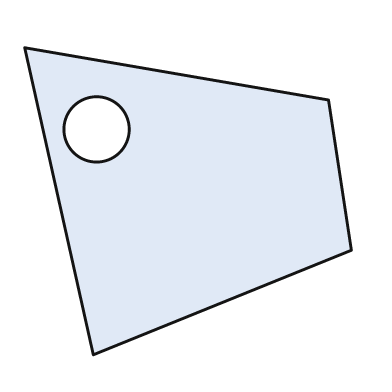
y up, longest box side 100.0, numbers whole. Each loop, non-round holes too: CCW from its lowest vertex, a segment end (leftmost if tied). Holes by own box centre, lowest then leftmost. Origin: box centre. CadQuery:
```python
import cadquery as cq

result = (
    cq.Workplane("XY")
    .moveTo(-29.0, -47.0)
    .lineTo(50.0, -15.0)
    .lineTo(43.0, 31.0)
    .lineTo(-50.0, 47.0)
    .close()
    .moveTo(-28.0, 22.0)
    .circle(10.0)
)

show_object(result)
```